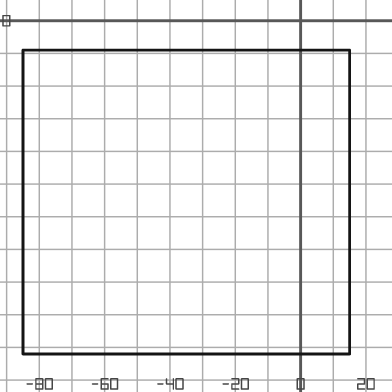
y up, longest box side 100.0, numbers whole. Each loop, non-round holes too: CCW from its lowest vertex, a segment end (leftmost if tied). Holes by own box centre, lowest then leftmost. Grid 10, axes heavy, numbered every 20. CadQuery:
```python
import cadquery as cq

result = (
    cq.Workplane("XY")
    .moveTo(-85.0, -102.0)
    .lineTo(15.0, -102.0)
    .lineTo(15.0, -9.0)
    .lineTo(-85.0, -9.0)
    .close()
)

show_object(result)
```